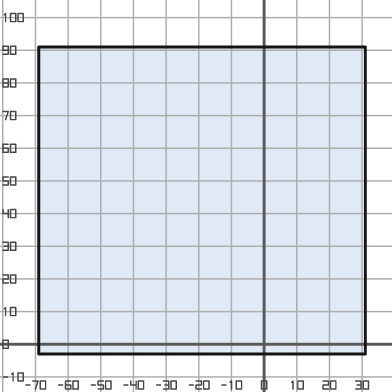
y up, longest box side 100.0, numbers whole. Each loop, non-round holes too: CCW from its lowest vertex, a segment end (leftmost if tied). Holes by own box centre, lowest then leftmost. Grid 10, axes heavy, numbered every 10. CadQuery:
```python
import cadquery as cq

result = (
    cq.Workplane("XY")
    .moveTo(-69.0, -3.0)
    .lineTo(31.0, -3.0)
    .lineTo(31.0, 91.0)
    .lineTo(-69.0, 91.0)
    .close()
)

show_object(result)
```